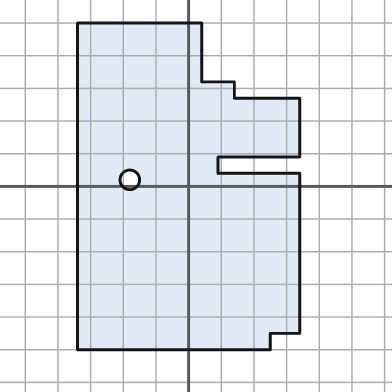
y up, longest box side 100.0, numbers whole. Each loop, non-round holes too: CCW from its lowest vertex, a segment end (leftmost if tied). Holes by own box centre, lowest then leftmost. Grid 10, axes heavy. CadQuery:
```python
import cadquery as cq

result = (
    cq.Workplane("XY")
    .moveTo(-34.0, -50.0)
    .lineTo(25.0, -50.0)
    .lineTo(25.0, -45.0)
    .lineTo(34.0, -45.0)
    .lineTo(34.0, 4.0)
    .lineTo(9.0, 4.0)
    .lineTo(9.0, 9.0)
    .lineTo(34.0, 9.0)
    .lineTo(34.0, 27.0)
    .lineTo(14.0, 27.0)
    .lineTo(14.0, 32.0)
    .lineTo(4.0, 32.0)
    .lineTo(4.0, 50.0)
    .lineTo(-34.0, 50.0)
    .close()
    .moveTo(-18.0, 2.0)
    .circle(3.0)
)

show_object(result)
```